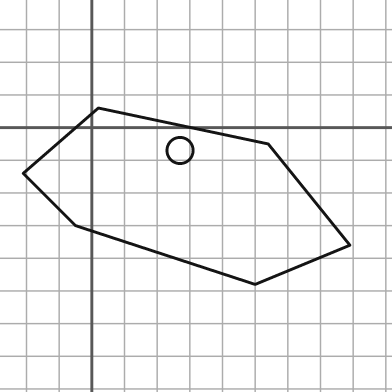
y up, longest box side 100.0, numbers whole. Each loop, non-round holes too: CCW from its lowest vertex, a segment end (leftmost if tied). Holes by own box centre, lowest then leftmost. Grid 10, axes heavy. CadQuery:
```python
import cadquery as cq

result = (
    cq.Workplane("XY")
    .moveTo(50.0, -48.0)
    .lineTo(79.0, -36.0)
    .lineTo(54.0, -5.0)
    .lineTo(2.0, 6.0)
    .lineTo(-21.0, -14.0)
    .lineTo(-5.0, -30.0)
    .close()
    .moveTo(27.0, -7.0)
    .circle(4.0)
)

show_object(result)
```